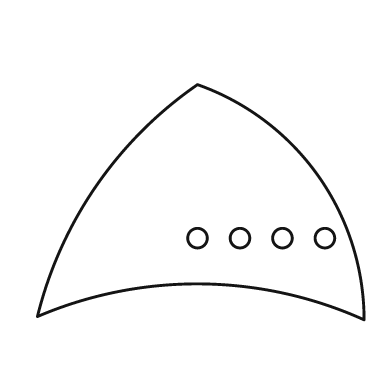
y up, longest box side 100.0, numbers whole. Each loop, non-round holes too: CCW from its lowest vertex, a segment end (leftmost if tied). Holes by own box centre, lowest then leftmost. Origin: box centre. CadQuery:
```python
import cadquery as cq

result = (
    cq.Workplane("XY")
    .moveTo(50.0, -36.0)
    .threePointArc((36.0, 8.0), (-1.0, 36.0))
    .threePointArc((-32.0, 5.0), (-50.0, -35.0))
    .threePointArc((0.0, -25.0), (50.0, -36.0))
    .close()
    .moveTo(-1.0, -11.0)
    .circle(3.0)
    .moveTo(12.0, -11.0)
    .circle(3.0)
    .moveTo(25.0, -11.0)
    .circle(3.0)
    .moveTo(38.0, -11.0)
    .circle(3.0)
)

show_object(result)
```